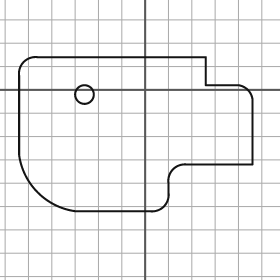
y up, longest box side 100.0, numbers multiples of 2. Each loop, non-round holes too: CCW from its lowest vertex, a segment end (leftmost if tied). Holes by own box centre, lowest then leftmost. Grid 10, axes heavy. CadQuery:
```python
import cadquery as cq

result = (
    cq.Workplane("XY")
    .moveTo(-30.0, -52.0)
    .lineTo(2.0, -52.0)
    .threePointArc((8.0, -50.0), (10.0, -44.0))
    .lineTo(10.0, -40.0)
    .threePointArc((12.0, -34.0), (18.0, -32.0))
    .lineTo(46.0, -32.0)
    .lineTo(46.0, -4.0)
    .threePointArc((44.0, 0.0), (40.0, 2.0))
    .lineTo(26.0, 2.0)
    .lineTo(26.0, 14.0)
    .lineTo(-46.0, 14.0)
    .threePointArc((-52.0, 12.0), (-54.0, 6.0))
    .lineTo(-54.0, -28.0)
    .threePointArc((-46.0, -44.0), (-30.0, -52.0))
    .close()
    .moveTo(-26.0, -2.0)
    .circle(4.0)
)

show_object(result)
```